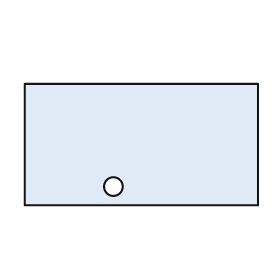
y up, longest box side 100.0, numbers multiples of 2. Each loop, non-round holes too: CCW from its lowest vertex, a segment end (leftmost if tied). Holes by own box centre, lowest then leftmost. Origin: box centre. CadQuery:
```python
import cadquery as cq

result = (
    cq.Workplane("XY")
    .moveTo(-50.0, -26.0)
    .lineTo(50.0, -26.0)
    .lineTo(50.0, 26.0)
    .lineTo(-50.0, 26.0)
    .close()
    .moveTo(-12.0, -18.0)
    .circle(4.0)
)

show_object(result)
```